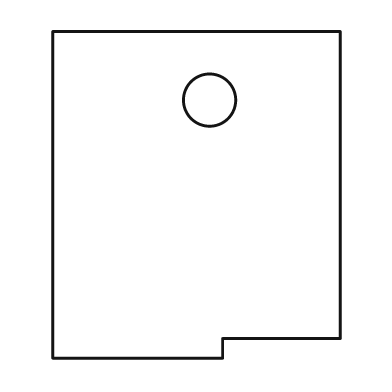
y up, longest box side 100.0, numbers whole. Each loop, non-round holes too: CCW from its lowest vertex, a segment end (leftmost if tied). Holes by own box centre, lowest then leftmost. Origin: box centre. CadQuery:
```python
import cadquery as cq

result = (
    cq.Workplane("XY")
    .moveTo(-44.0, -50.0)
    .lineTo(8.0, -50.0)
    .lineTo(8.0, -44.0)
    .lineTo(44.0, -44.0)
    .lineTo(44.0, 50.0)
    .lineTo(-44.0, 50.0)
    .close()
    .moveTo(4.0, 29.0)
    .circle(8.0)
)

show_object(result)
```